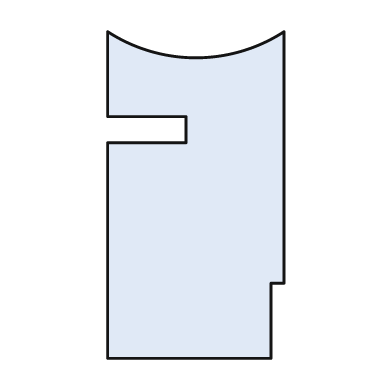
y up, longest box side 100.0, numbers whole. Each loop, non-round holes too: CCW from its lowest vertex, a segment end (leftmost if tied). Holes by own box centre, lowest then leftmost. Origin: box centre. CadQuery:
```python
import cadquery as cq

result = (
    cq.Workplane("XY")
    .moveTo(-27.0, -50.0)
    .lineTo(23.0, -50.0)
    .lineTo(23.0, -27.0)
    .lineTo(27.0, -27.0)
    .lineTo(27.0, 50.0)
    .threePointArc((0.0, 42.0), (-27.0, 50.0))
    .lineTo(-27.0, 24.0)
    .lineTo(-3.0, 24.0)
    .lineTo(-3.0, 16.0)
    .lineTo(-27.0, 16.0)
    .close()
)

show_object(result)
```